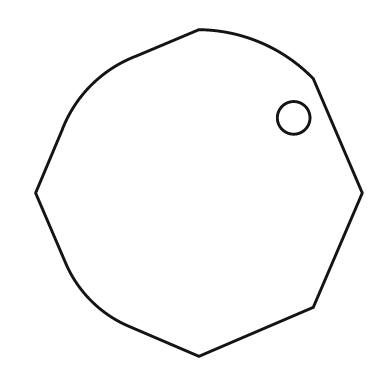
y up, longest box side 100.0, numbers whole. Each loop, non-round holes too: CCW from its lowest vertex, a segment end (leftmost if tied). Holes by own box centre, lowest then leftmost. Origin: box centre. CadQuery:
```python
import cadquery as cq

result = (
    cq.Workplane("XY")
    .moveTo(0.0, -50.0)
    .lineTo(35.0, -35.0)
    .lineTo(50.0, 0.0)
    .lineTo(35.0, 35.0)
    .threePointArc((19.0, 46.0), (0.0, 50.0))
    .lineTo(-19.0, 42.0)
    .threePointArc((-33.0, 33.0), (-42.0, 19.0))
    .lineTo(-50.0, 0.0)
    .lineTo(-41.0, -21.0)
    .threePointArc((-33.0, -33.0), (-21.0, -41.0))
    .close()
    .moveTo(29.0, 23.0)
    .circle(5.0)
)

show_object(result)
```